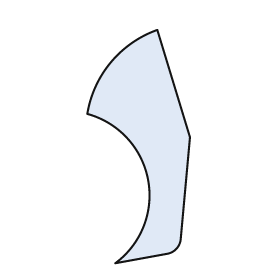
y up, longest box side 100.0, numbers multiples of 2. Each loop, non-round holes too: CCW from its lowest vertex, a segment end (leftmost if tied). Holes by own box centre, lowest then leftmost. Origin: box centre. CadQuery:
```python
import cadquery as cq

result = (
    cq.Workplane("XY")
    .moveTo(-10.0, -50.0)
    .lineTo(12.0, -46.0)
    .threePointArc((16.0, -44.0), (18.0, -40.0))
    .lineTo(22.0, 4.0)
    .lineTo(8.0, 50.0)
    .threePointArc((-12.0, 36.0), (-22.0, 14.0))
    .threePointArc((4.0, -14.0), (-10.0, -50.0))
    .close()
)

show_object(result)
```